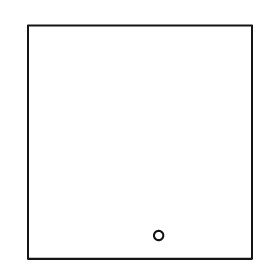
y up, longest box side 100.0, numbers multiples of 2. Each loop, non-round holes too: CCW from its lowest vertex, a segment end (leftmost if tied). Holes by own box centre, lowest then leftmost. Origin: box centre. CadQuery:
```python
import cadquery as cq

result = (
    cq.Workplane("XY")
    .moveTo(-48.0, -50.0)
    .lineTo(48.0, -50.0)
    .lineTo(48.0, 50.0)
    .lineTo(-48.0, 50.0)
    .close()
    .moveTo(8.0, -40.0)
    .circle(2.0)
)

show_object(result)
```